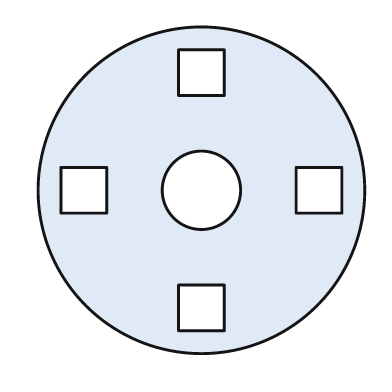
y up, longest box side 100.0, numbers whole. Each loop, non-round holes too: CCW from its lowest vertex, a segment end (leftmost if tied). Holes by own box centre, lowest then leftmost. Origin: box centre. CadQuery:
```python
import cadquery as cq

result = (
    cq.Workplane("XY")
    .moveTo(0.0, 0.0)
    .circle(50.0)
    .moveTo(-7.0, -43.0)
    .lineTo(7.0, -43.0)
    .lineTo(7.0, -29.0)
    .lineTo(-7.0, -29.0)
    .close()
    .moveTo(-43.0, -7.0)
    .lineTo(-29.0, -7.0)
    .lineTo(-29.0, 7.0)
    .lineTo(-43.0, 7.0)
    .close()
    .moveTo(0.0, 0.0)
    .circle(12.0)
    .moveTo(29.0, -7.0)
    .lineTo(43.0, -7.0)
    .lineTo(43.0, 7.0)
    .lineTo(29.0, 7.0)
    .close()
    .moveTo(-7.0, 29.0)
    .lineTo(7.0, 29.0)
    .lineTo(7.0, 43.0)
    .lineTo(-7.0, 43.0)
    .close()
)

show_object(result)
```